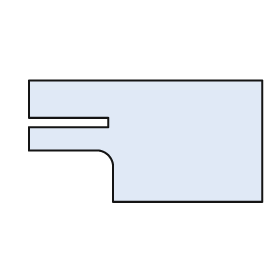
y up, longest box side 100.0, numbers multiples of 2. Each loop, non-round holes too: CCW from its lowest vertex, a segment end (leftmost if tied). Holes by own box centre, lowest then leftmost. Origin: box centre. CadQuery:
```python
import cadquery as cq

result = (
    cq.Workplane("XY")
    .moveTo(-14.0, -26.0)
    .lineTo(50.0, -26.0)
    .lineTo(50.0, 26.0)
    .lineTo(-50.0, 26.0)
    .lineTo(-50.0, 10.0)
    .lineTo(-16.0, 10.0)
    .lineTo(-16.0, 6.0)
    .lineTo(-50.0, 6.0)
    .lineTo(-50.0, -4.0)
    .lineTo(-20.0, -4.0)
    .threePointArc((-16.0, -6.0), (-14.0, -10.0))
    .close()
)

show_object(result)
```